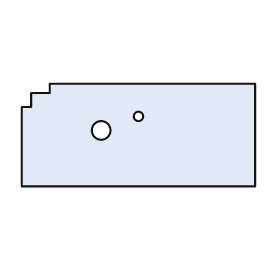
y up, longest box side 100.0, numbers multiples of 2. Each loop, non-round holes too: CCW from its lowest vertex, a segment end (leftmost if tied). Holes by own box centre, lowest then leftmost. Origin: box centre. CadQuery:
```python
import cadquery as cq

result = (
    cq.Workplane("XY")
    .moveTo(-50.0, -22.0)
    .lineTo(50.0, -22.0)
    .lineTo(50.0, 22.0)
    .lineTo(-38.0, 22.0)
    .lineTo(-38.0, 18.0)
    .lineTo(-46.0, 18.0)
    .lineTo(-46.0, 12.0)
    .lineTo(-50.0, 12.0)
    .close()
    .moveTo(-16.0, 2.0)
    .circle(4.0)
    .moveTo(0.0, 8.0)
    .circle(2.0)
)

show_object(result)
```